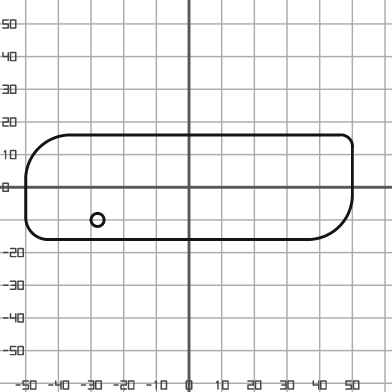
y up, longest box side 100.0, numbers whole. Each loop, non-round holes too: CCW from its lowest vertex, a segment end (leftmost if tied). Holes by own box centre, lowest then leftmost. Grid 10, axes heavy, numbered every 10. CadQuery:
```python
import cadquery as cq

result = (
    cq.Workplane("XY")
    .moveTo(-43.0, -16.0)
    .lineTo(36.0, -16.0)
    .threePointArc((46.0, -12.0), (50.0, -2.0))
    .lineTo(50.0, 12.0)
    .threePointArc((49.0, 15.0), (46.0, 16.0))
    .lineTo(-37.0, 16.0)
    .threePointArc((-46.0, 12.0), (-50.0, 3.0))
    .lineTo(-50.0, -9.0)
    .threePointArc((-48.0, -14.0), (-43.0, -16.0))
    .close()
    .moveTo(-28.0, -10.0)
    .circle(2.0)
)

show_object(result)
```